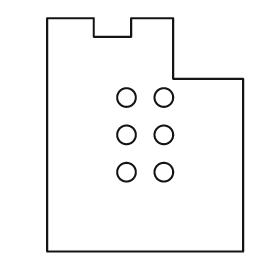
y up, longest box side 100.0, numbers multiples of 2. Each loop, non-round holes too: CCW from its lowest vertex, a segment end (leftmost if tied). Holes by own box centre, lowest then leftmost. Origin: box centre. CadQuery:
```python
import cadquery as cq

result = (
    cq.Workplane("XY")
    .moveTo(-42.0, -50.0)
    .lineTo(42.0, -50.0)
    .lineTo(42.0, 24.0)
    .lineTo(12.0, 24.0)
    .lineTo(12.0, 50.0)
    .lineTo(-6.0, 50.0)
    .lineTo(-6.0, 42.0)
    .lineTo(-22.0, 42.0)
    .lineTo(-22.0, 50.0)
    .lineTo(-42.0, 50.0)
    .close()
    .moveTo(-8.0, -16.0)
    .circle(4.0)
    .moveTo(8.0, -16.0)
    .circle(4.0)
    .moveTo(-8.0, 0.0)
    .circle(4.0)
    .moveTo(8.0, 0.0)
    .circle(4.0)
    .moveTo(-8.0, 16.0)
    .circle(4.0)
    .moveTo(8.0, 16.0)
    .circle(4.0)
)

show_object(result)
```